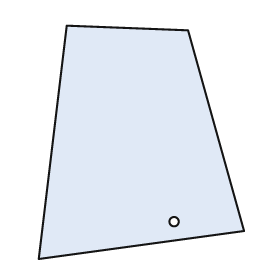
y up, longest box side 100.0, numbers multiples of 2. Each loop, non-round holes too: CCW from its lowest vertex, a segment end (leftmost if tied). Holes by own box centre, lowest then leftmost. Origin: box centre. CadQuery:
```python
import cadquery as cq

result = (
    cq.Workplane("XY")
    .moveTo(-44.0, -50.0)
    .lineTo(44.0, -38.0)
    .lineTo(20.0, 48.0)
    .lineTo(-32.0, 50.0)
    .close()
    .moveTo(14.0, -34.0)
    .circle(2.0)
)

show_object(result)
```